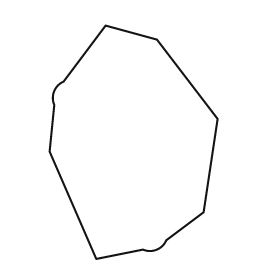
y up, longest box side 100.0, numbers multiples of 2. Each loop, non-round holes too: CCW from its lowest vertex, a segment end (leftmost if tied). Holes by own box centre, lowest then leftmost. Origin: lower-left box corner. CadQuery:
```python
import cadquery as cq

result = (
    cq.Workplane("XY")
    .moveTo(20.0, 0.0)
    .lineTo(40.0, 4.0)
    .threePointArc((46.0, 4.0), (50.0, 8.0))
    .lineTo(66.0, 20.0)
    .lineTo(72.0, 60.0)
    .lineTo(46.0, 94.0)
    .lineTo(24.0, 100.0)
    .lineTo(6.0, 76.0)
    .threePointArc((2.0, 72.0), (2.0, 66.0))
    .lineTo(0.0, 46.0)
    .close()
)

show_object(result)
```